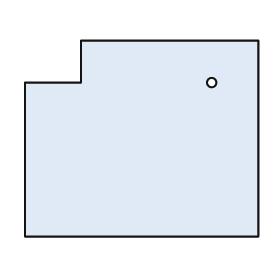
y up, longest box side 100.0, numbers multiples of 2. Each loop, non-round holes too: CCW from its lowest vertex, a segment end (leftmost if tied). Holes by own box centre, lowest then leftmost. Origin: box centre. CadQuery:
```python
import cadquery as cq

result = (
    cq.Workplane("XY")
    .moveTo(-50.0, -42.0)
    .lineTo(50.0, -42.0)
    .lineTo(50.0, 42.0)
    .lineTo(-26.0, 42.0)
    .lineTo(-26.0, 24.0)
    .lineTo(-50.0, 24.0)
    .close()
    .moveTo(30.0, 24.0)
    .circle(2.0)
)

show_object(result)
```